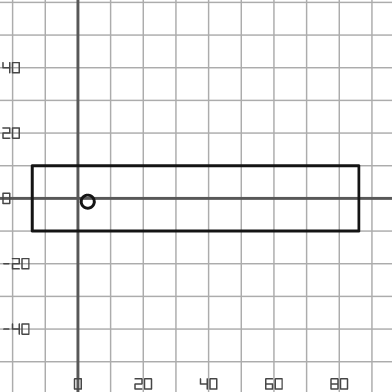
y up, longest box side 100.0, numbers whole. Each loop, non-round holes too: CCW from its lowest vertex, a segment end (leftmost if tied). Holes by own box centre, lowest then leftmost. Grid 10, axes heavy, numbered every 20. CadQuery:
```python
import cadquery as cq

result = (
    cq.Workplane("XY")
    .moveTo(-14.0, -10.0)
    .lineTo(86.0, -10.0)
    .lineTo(86.0, 10.0)
    .lineTo(-14.0, 10.0)
    .close()
    .moveTo(3.0, -1.0)
    .circle(2.0)
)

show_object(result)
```